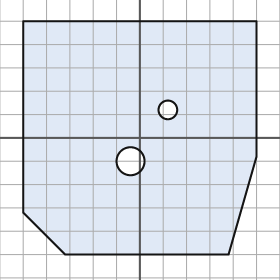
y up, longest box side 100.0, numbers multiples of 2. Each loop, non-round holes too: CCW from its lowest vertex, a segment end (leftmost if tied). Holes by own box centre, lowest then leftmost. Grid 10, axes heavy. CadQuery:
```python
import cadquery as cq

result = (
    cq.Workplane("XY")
    .moveTo(-32.0, -50.0)
    .lineTo(38.0, -50.0)
    .lineTo(50.0, -8.0)
    .lineTo(50.0, 50.0)
    .lineTo(-50.0, 50.0)
    .lineTo(-50.0, -32.0)
    .close()
    .moveTo(-4.0, -10.0)
    .circle(6.0)
    .moveTo(12.0, 12.0)
    .circle(4.0)
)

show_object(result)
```